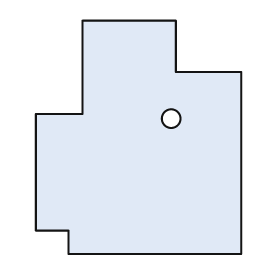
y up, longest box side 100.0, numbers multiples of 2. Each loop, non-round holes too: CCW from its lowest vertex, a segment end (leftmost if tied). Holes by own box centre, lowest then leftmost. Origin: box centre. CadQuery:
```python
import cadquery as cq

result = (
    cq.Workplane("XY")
    .moveTo(-30.0, -50.0)
    .lineTo(44.0, -50.0)
    .lineTo(44.0, 28.0)
    .lineTo(16.0, 28.0)
    .lineTo(16.0, 50.0)
    .lineTo(-24.0, 50.0)
    .lineTo(-24.0, 10.0)
    .lineTo(-44.0, 10.0)
    .lineTo(-44.0, -40.0)
    .lineTo(-30.0, -40.0)
    .close()
    .moveTo(14.0, 8.0)
    .circle(4.0)
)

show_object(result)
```